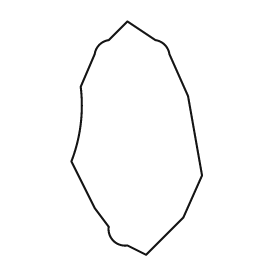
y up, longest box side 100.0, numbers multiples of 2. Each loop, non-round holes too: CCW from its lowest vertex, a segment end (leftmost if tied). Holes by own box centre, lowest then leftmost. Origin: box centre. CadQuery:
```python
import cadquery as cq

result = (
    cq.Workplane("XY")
    .moveTo(4.0, -50.0)
    .lineTo(20.0, -34.0)
    .lineTo(28.0, -16.0)
    .lineTo(22.0, 18.0)
    .lineTo(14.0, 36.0)
    .threePointArc((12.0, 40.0), (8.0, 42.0))
    .lineTo(-4.0, 50.0)
    .lineTo(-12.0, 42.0)
    .threePointArc((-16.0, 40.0), (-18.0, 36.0))
    .lineTo(-24.0, 22.0)
    .threePointArc((-24.0, 6.0), (-28.0, -10.0))
    .lineTo(-18.0, -30.0)
    .lineTo(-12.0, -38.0)
    .threePointArc((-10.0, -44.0), (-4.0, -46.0))
    .close()
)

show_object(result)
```